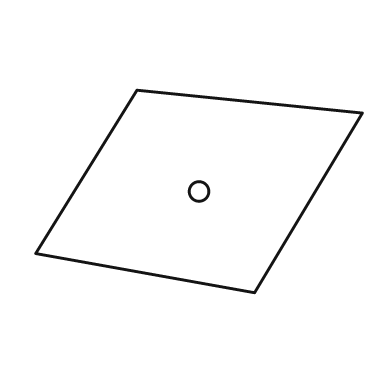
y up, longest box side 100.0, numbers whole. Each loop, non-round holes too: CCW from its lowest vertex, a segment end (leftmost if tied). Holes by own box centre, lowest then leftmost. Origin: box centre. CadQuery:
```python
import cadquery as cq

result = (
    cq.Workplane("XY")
    .moveTo(17.0, -31.0)
    .lineTo(50.0, 24.0)
    .lineTo(-19.0, 31.0)
    .lineTo(-50.0, -19.0)
    .close()
    .moveTo(0.0, 0.0)
    .circle(3.0)
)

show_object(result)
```